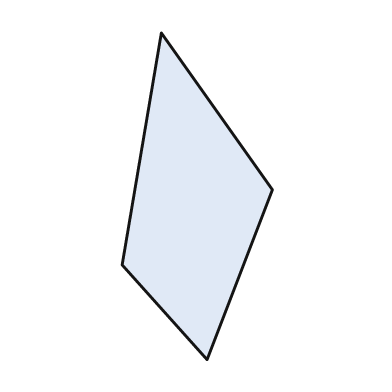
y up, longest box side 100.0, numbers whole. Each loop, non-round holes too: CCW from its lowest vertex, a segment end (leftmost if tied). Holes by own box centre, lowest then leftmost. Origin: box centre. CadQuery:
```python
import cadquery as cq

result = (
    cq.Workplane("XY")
    .moveTo(3.0, -50.0)
    .lineTo(23.0, 2.0)
    .lineTo(-11.0, 50.0)
    .lineTo(-23.0, -21.0)
    .close()
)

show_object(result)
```